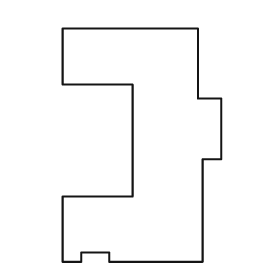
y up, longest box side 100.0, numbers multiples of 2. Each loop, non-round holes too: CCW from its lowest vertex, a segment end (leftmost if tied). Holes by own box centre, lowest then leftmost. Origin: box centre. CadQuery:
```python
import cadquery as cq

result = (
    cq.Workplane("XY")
    .moveTo(-34.0, -50.0)
    .lineTo(-26.0, -50.0)
    .lineTo(-26.0, -46.0)
    .lineTo(-14.0, -46.0)
    .lineTo(-14.0, -50.0)
    .lineTo(26.0, -50.0)
    .lineTo(26.0, -6.0)
    .lineTo(34.0, -6.0)
    .lineTo(34.0, 20.0)
    .lineTo(24.0, 20.0)
    .lineTo(24.0, 50.0)
    .lineTo(-34.0, 50.0)
    .lineTo(-34.0, 26.0)
    .lineTo(-4.0, 26.0)
    .lineTo(-4.0, -22.0)
    .lineTo(-34.0, -22.0)
    .close()
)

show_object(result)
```